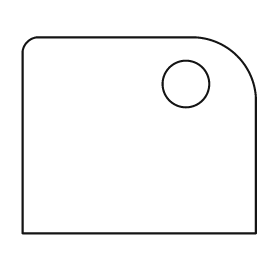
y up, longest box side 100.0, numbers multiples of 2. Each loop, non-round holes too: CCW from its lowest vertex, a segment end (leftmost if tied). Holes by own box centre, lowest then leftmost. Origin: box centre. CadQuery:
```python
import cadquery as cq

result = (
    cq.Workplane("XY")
    .moveTo(-50.0, -42.0)
    .lineTo(50.0, -42.0)
    .lineTo(50.0, 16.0)
    .threePointArc((42.0, 34.0), (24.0, 42.0))
    .lineTo(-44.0, 42.0)
    .threePointArc((-48.0, 40.0), (-50.0, 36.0))
    .close()
    .moveTo(20.0, 22.0)
    .circle(10.0)
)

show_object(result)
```